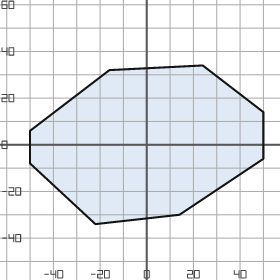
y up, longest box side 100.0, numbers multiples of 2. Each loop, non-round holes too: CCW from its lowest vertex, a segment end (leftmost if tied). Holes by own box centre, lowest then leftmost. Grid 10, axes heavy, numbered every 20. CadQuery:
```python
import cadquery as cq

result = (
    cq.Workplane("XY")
    .moveTo(-22.0, -34.0)
    .lineTo(14.0, -30.0)
    .lineTo(50.0, -6.0)
    .lineTo(50.0, 14.0)
    .lineTo(24.0, 34.0)
    .lineTo(-16.0, 32.0)
    .lineTo(-50.0, 6.0)
    .lineTo(-50.0, -8.0)
    .close()
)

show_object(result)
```